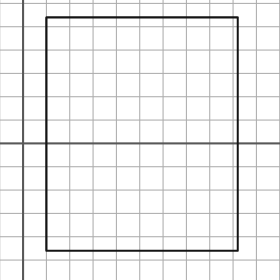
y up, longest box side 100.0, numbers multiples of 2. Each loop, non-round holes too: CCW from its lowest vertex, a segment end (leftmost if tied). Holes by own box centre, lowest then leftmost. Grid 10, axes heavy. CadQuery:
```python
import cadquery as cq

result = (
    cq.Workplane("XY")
    .moveTo(10.0, -46.0)
    .lineTo(92.0, -46.0)
    .lineTo(92.0, 54.0)
    .lineTo(10.0, 54.0)
    .close()
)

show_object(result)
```